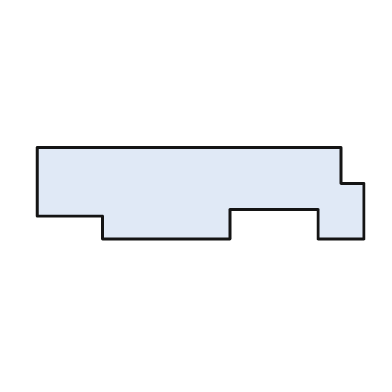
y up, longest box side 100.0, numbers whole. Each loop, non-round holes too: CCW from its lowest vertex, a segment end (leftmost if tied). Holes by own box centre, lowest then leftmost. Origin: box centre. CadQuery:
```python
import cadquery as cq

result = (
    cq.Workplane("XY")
    .moveTo(-30.0, -14.0)
    .lineTo(9.0, -14.0)
    .lineTo(9.0, -5.0)
    .lineTo(36.0, -5.0)
    .lineTo(36.0, -14.0)
    .lineTo(50.0, -14.0)
    .lineTo(50.0, 3.0)
    .lineTo(43.0, 3.0)
    .lineTo(43.0, 14.0)
    .lineTo(-50.0, 14.0)
    .lineTo(-50.0, -7.0)
    .lineTo(-30.0, -7.0)
    .close()
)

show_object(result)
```